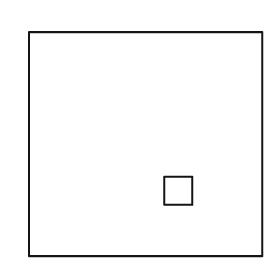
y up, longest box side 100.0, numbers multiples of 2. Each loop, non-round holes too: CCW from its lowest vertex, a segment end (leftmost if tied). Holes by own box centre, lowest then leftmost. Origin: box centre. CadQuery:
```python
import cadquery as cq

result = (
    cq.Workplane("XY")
    .moveTo(-50.0, -48.0)
    .lineTo(50.0, -48.0)
    .lineTo(50.0, 48.0)
    .lineTo(-50.0, 48.0)
    .close()
    .moveTo(8.0, -26.0)
    .lineTo(20.0, -26.0)
    .lineTo(20.0, -14.0)
    .lineTo(8.0, -14.0)
    .close()
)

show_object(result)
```